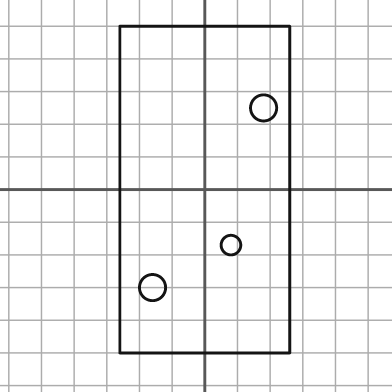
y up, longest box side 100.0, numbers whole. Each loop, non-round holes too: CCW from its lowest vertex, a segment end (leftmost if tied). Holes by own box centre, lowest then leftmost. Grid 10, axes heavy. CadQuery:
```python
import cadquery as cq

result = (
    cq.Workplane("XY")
    .moveTo(-26.0, -50.0)
    .lineTo(26.0, -50.0)
    .lineTo(26.0, 50.0)
    .lineTo(-26.0, 50.0)
    .close()
    .moveTo(-16.0, -30.0)
    .circle(4.0)
    .moveTo(8.0, -17.0)
    .circle(3.0)
    .moveTo(18.0, 25.0)
    .circle(4.0)
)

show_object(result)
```